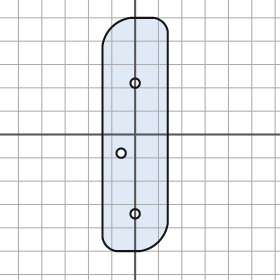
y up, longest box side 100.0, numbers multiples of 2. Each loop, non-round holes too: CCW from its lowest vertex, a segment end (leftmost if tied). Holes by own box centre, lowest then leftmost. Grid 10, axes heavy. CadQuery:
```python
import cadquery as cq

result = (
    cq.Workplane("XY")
    .moveTo(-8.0, -50.0)
    .lineTo(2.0, -50.0)
    .threePointArc((10.0, -46.0), (14.0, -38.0))
    .lineTo(14.0, 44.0)
    .threePointArc((12.0, 48.0), (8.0, 50.0))
    .lineTo(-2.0, 50.0)
    .threePointArc((-10.0, 46.0), (-14.0, 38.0))
    .lineTo(-14.0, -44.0)
    .threePointArc((-12.0, -48.0), (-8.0, -50.0))
    .close()
    .moveTo(0.0, -34.0)
    .circle(2.0)
    .moveTo(-6.0, -8.0)
    .circle(2.0)
    .moveTo(0.0, 22.0)
    .circle(2.0)
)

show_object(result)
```